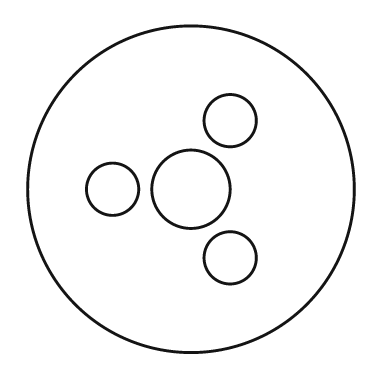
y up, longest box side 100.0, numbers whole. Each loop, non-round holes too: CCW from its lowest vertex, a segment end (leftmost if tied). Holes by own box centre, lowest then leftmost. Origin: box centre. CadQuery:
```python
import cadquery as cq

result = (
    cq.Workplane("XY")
    .moveTo(0.0, 0.0)
    .circle(50.0)
    .moveTo(12.0, -21.0)
    .circle(8.0)
    .moveTo(-24.0, 0.0)
    .circle(8.0)
    .moveTo(0.0, 0.0)
    .circle(12.0)
    .moveTo(12.0, 21.0)
    .circle(8.0)
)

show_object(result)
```